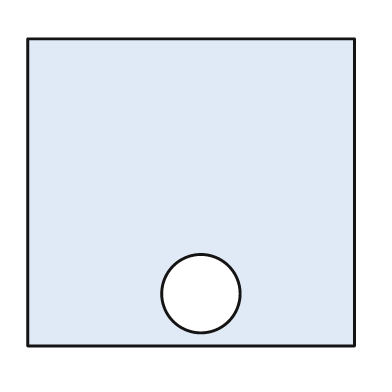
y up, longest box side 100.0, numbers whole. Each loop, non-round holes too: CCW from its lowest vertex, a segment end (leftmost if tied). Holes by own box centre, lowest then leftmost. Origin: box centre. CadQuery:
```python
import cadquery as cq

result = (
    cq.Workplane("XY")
    .moveTo(-50.0, -47.0)
    .lineTo(50.0, -47.0)
    .lineTo(50.0, 47.0)
    .lineTo(-50.0, 47.0)
    .close()
    .moveTo(3.0, -31.0)
    .circle(12.0)
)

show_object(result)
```